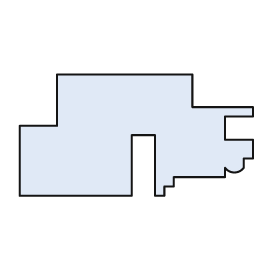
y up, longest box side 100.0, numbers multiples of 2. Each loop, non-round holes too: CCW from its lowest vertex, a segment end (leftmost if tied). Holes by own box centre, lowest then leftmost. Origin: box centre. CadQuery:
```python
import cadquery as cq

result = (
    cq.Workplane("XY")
    .moveTo(-50.0, -26.0)
    .lineTo(-2.0, -26.0)
    .lineTo(-2.0, 0.0)
    .lineTo(8.0, 0.0)
    .lineTo(8.0, -26.0)
    .lineTo(12.0, -26.0)
    .lineTo(12.0, -22.0)
    .lineTo(16.0, -22.0)
    .lineTo(16.0, -18.0)
    .lineTo(38.0, -18.0)
    .lineTo(38.0, -14.0)
    .threePointArc((42.0, -16.0), (46.0, -14.0))
    .lineTo(46.0, -10.0)
    .lineTo(50.0, -10.0)
    .lineTo(50.0, -2.0)
    .lineTo(38.0, -2.0)
    .lineTo(38.0, 8.0)
    .lineTo(50.0, 8.0)
    .lineTo(50.0, 12.0)
    .lineTo(24.0, 12.0)
    .lineTo(24.0, 26.0)
    .lineTo(-34.0, 26.0)
    .lineTo(-34.0, 4.0)
    .lineTo(-50.0, 4.0)
    .close()
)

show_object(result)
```